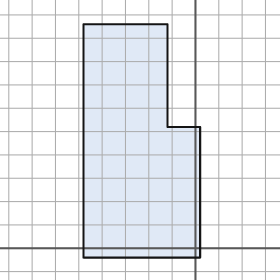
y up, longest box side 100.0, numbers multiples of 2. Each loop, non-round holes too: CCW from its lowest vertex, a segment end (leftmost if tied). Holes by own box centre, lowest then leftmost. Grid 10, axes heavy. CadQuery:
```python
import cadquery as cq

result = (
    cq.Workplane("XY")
    .moveTo(-48.0, -4.0)
    .lineTo(2.0, -4.0)
    .lineTo(2.0, 52.0)
    .lineTo(-12.0, 52.0)
    .lineTo(-12.0, 96.0)
    .lineTo(-48.0, 96.0)
    .close()
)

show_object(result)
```